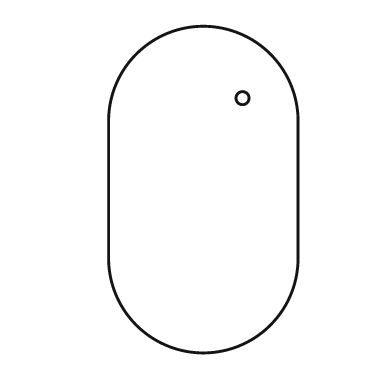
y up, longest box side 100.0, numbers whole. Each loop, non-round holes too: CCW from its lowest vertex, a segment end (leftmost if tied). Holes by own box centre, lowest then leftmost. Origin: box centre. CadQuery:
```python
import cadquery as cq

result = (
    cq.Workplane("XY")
    .moveTo(-29.0, -21.0)
    .threePointArc((0.0, -50.0), (29.0, -21.0))
    .lineTo(29.0, 21.0)
    .threePointArc((0.0, 50.0), (-29.0, 21.0))
    .close()
    .moveTo(12.0, 28.0)
    .circle(2.0)
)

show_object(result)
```